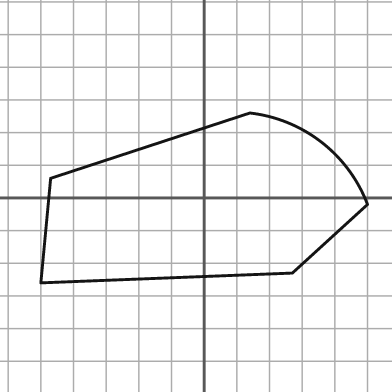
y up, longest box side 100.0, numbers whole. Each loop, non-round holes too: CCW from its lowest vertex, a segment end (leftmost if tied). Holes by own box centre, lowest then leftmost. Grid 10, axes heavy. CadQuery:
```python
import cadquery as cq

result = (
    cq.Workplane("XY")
    .moveTo(-50.0, -26.0)
    .lineTo(27.0, -23.0)
    .lineTo(50.0, -2.0)
    .threePointArc((36.0, 17.0), (14.0, 26.0))
    .lineTo(-47.0, 6.0)
    .close()
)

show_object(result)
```